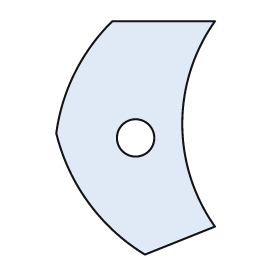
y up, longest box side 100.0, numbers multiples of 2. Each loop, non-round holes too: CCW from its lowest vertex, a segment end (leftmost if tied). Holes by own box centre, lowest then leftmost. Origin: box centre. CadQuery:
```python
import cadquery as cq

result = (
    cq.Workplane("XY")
    .moveTo(4.0, -50.0)
    .lineTo(34.0, -38.0)
    .threePointArc((20.0, 6.0), (34.0, 50.0))
    .lineTo(-10.0, 50.0)
    .threePointArc((-26.0, 28.0), (-34.0, 2.0))
    .threePointArc((-20.0, -28.0), (4.0, -50.0))
    .close()
    .moveTo(0.0, 0.0)
    .circle(8.0)
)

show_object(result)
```